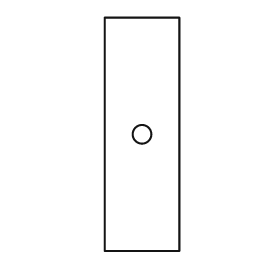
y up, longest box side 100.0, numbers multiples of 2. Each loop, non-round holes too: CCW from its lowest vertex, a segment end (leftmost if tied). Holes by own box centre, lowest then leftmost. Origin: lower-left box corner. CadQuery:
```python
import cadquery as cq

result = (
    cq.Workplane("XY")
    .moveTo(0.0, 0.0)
    .lineTo(32.0, 0.0)
    .lineTo(32.0, 100.0)
    .lineTo(0.0, 100.0)
    .close()
    .moveTo(16.0, 50.0)
    .circle(4.0)
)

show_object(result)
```